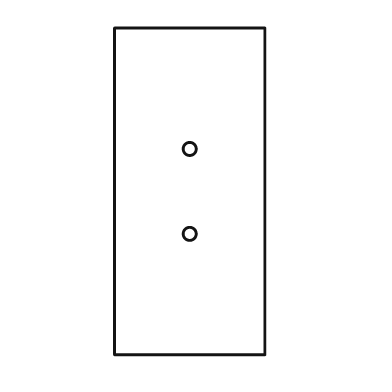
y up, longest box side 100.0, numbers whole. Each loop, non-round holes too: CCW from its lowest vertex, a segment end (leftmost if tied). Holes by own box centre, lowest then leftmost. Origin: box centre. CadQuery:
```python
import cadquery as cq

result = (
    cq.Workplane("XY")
    .moveTo(-23.0, -50.0)
    .lineTo(23.0, -50.0)
    .lineTo(23.0, 50.0)
    .lineTo(-23.0, 50.0)
    .close()
    .moveTo(0.0, -13.0)
    .circle(2.0)
    .moveTo(0.0, 13.0)
    .circle(2.0)
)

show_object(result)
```